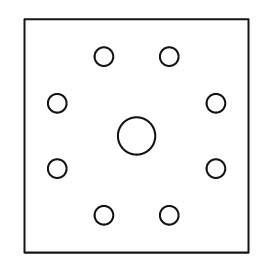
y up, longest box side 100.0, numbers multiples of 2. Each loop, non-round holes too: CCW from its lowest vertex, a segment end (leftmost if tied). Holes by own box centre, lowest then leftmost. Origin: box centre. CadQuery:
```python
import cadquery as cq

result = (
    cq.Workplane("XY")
    .moveTo(-48.0, -50.0)
    .lineTo(48.0, -50.0)
    .lineTo(48.0, 50.0)
    .lineTo(-48.0, 50.0)
    .close()
    .moveTo(-14.0, -34.0)
    .circle(4.0)
    .moveTo(14.0, -34.0)
    .circle(4.0)
    .moveTo(-34.0, -14.0)
    .circle(4.0)
    .moveTo(34.0, -14.0)
    .circle(4.0)
    .moveTo(0.0, 0.0)
    .circle(8.0)
    .moveTo(-34.0, 14.0)
    .circle(4.0)
    .moveTo(34.0, 14.0)
    .circle(4.0)
    .moveTo(-14.0, 34.0)
    .circle(4.0)
    .moveTo(14.0, 34.0)
    .circle(4.0)
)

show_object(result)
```